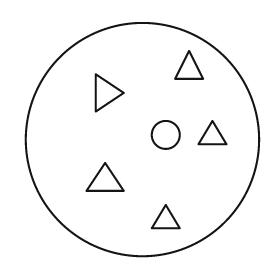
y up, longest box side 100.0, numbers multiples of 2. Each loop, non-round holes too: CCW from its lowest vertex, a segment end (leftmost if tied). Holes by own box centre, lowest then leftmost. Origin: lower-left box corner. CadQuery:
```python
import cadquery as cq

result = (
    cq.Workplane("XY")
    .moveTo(50.0, 50.0)
    .circle(50.0)
    .moveTo(54.0, 12.0)
    .lineTo(66.0, 12.0)
    .lineTo(60.0, 22.0)
    .close()
    .moveTo(26.0, 28.0)
    .lineTo(42.0, 28.0)
    .lineTo(34.0, 40.0)
    .close()
    .moveTo(60.0, 52.0)
    .circle(6.0)
    .moveTo(74.0, 48.0)
    .lineTo(86.0, 48.0)
    .lineTo(80.0, 58.0)
    .close()
    .moveTo(30.0, 62.0)
    .lineTo(42.0, 70.0)
    .lineTo(30.0, 78.0)
    .close()
    .moveTo(64.0, 76.0)
    .lineTo(76.0, 76.0)
    .lineTo(70.0, 88.0)
    .close()
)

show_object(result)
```